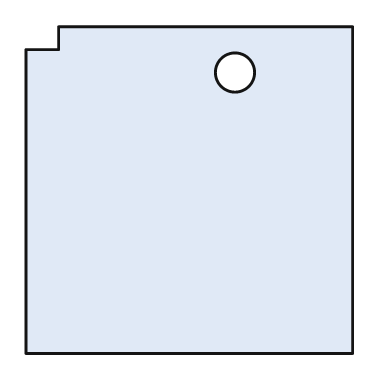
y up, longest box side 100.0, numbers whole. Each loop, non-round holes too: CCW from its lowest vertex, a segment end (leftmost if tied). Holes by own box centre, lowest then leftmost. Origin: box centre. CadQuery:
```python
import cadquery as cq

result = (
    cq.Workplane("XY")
    .moveTo(-50.0, -50.0)
    .lineTo(50.0, -50.0)
    .lineTo(50.0, 50.0)
    .lineTo(-40.0, 50.0)
    .lineTo(-40.0, 43.0)
    .lineTo(-50.0, 43.0)
    .close()
    .moveTo(14.0, 36.0)
    .circle(6.0)
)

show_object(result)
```